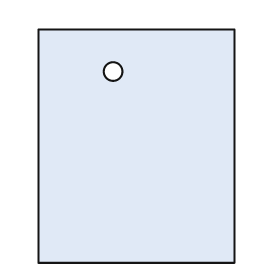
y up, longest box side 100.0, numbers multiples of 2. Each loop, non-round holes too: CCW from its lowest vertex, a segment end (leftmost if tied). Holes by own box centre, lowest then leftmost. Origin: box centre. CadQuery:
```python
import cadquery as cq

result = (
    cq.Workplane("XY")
    .moveTo(-42.0, -50.0)
    .lineTo(42.0, -50.0)
    .lineTo(42.0, 50.0)
    .lineTo(-42.0, 50.0)
    .close()
    .moveTo(-10.0, 32.0)
    .circle(4.0)
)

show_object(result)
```